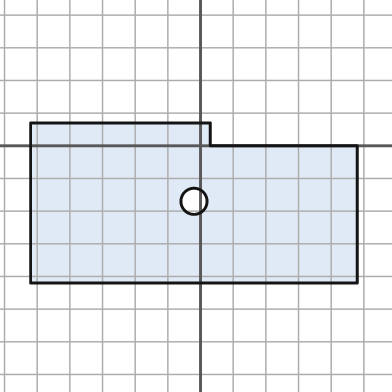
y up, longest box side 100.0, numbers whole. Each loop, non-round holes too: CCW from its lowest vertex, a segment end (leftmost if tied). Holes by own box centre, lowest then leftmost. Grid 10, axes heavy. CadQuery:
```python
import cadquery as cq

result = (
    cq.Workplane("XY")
    .moveTo(-52.0, -42.0)
    .lineTo(48.0, -42.0)
    .lineTo(48.0, 0.0)
    .lineTo(3.0, 0.0)
    .lineTo(3.0, 7.0)
    .lineTo(-52.0, 7.0)
    .close()
    .moveTo(-2.0, -17.0)
    .circle(4.0)
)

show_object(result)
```